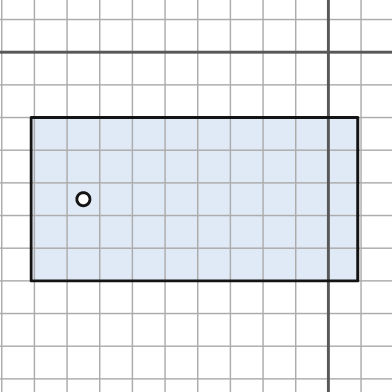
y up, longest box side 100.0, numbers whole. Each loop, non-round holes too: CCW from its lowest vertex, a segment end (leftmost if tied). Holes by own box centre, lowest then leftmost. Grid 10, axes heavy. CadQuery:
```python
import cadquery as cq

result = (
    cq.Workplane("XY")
    .moveTo(-91.0, -70.0)
    .lineTo(9.0, -70.0)
    .lineTo(9.0, -20.0)
    .lineTo(-91.0, -20.0)
    .close()
    .moveTo(-75.0, -45.0)
    .circle(2.0)
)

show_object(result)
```